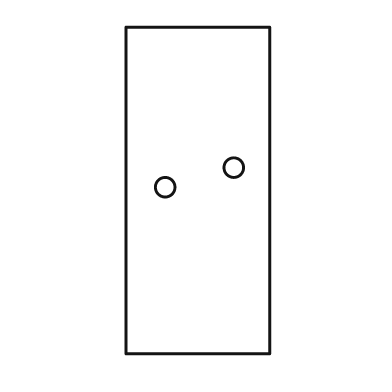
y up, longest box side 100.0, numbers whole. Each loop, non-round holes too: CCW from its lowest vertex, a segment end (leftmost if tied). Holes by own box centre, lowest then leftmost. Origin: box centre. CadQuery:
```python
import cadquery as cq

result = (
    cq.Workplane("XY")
    .moveTo(-22.0, -50.0)
    .lineTo(22.0, -50.0)
    .lineTo(22.0, 50.0)
    .lineTo(-22.0, 50.0)
    .close()
    .moveTo(-10.0, 1.0)
    .circle(3.0)
    .moveTo(11.0, 7.0)
    .circle(3.0)
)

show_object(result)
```